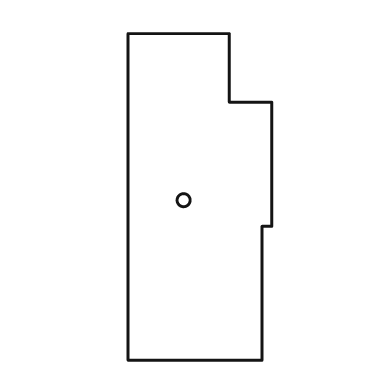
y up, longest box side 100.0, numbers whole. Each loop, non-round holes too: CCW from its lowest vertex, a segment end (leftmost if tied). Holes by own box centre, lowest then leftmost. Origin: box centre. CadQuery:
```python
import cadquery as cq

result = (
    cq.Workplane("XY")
    .moveTo(-22.0, -50.0)
    .lineTo(19.0, -50.0)
    .lineTo(19.0, -9.0)
    .lineTo(22.0, -9.0)
    .lineTo(22.0, 29.0)
    .lineTo(9.0, 29.0)
    .lineTo(9.0, 50.0)
    .lineTo(-22.0, 50.0)
    .close()
    .moveTo(-5.0, -1.0)
    .circle(2.0)
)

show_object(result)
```